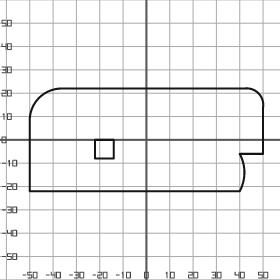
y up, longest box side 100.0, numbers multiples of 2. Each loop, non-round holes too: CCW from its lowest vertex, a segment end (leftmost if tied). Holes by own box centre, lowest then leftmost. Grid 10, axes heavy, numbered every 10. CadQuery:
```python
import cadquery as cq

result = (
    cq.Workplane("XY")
    .moveTo(-50.0, -22.0)
    .lineTo(40.0, -22.0)
    .threePointArc((42.0, -14.0), (40.0, -6.0))
    .lineTo(50.0, -6.0)
    .lineTo(50.0, 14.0)
    .threePointArc((48.0, 20.0), (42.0, 22.0))
    .lineTo(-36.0, 22.0)
    .threePointArc((-46.0, 18.0), (-50.0, 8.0))
    .close()
    .moveTo(-22.0, -8.0)
    .lineTo(-14.0, -8.0)
    .lineTo(-14.0, 0.0)
    .lineTo(-22.0, 0.0)
    .close()
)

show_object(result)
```